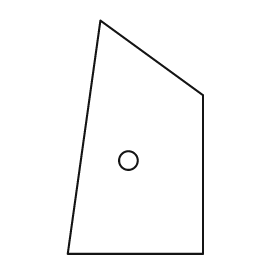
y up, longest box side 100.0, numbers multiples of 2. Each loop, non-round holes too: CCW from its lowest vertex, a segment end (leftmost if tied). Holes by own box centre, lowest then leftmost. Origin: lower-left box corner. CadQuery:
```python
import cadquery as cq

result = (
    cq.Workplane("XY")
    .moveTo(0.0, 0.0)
    .lineTo(58.0, 0.0)
    .lineTo(58.0, 68.0)
    .lineTo(14.0, 100.0)
    .close()
    .moveTo(26.0, 40.0)
    .circle(4.0)
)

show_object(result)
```